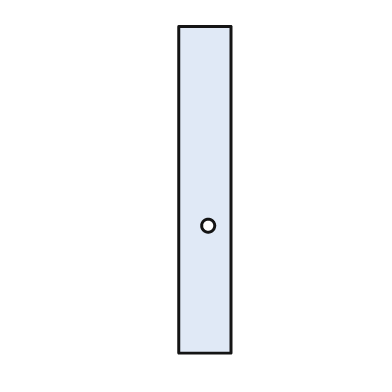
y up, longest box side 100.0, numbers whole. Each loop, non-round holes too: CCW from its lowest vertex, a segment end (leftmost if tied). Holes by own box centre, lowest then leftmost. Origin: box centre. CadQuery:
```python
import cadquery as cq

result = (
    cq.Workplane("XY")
    .moveTo(-8.0, -50.0)
    .lineTo(8.0, -50.0)
    .lineTo(8.0, 50.0)
    .lineTo(-8.0, 50.0)
    .close()
    .moveTo(1.0, -11.0)
    .circle(2.0)
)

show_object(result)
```